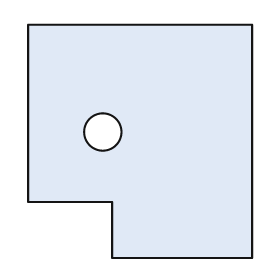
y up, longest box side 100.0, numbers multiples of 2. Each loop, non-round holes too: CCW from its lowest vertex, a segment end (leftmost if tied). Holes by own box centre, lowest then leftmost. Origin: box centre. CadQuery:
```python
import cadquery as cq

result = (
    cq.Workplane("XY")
    .moveTo(-12.0, -50.0)
    .lineTo(48.0, -50.0)
    .lineTo(48.0, 50.0)
    .lineTo(-48.0, 50.0)
    .lineTo(-48.0, -26.0)
    .lineTo(-12.0, -26.0)
    .close()
    .moveTo(-16.0, 4.0)
    .circle(8.0)
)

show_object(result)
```